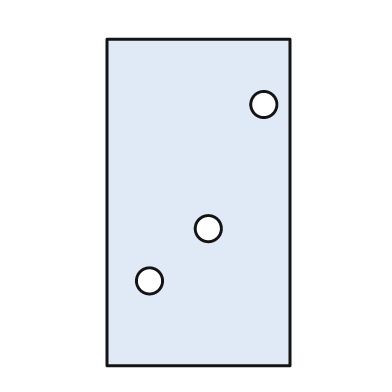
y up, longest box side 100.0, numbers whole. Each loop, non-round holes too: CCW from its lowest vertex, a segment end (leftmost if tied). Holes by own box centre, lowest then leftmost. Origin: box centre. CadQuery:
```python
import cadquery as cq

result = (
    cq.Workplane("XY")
    .moveTo(-28.0, -50.0)
    .lineTo(28.0, -50.0)
    .lineTo(28.0, 50.0)
    .lineTo(-28.0, 50.0)
    .close()
    .moveTo(-15.0, -24.0)
    .circle(4.0)
    .moveTo(3.0, -8.0)
    .circle(4.0)
    .moveTo(20.0, 30.0)
    .circle(4.0)
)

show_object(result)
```